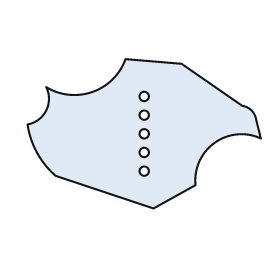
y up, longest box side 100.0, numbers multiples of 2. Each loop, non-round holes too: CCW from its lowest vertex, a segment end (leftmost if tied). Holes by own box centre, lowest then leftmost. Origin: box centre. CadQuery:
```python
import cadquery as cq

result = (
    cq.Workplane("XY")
    .moveTo(4.0, -32.0)
    .lineTo(22.0, -22.0)
    .threePointArc((30.0, -4.0), (50.0, -2.0))
    .lineTo(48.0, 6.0)
    .threePointArc((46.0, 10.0), (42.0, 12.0))
    .lineTo(16.0, 30.0)
    .lineTo(-8.0, 32.0)
    .threePointArc((-22.0, 18.0), (-42.0, 20.0))
    .threePointArc((-42.0, 10.0), (-50.0, 4.0))
    .threePointArc((-46.0, -8.0), (-38.0, -18.0))
    .close()
    .moveTo(0.0, -16.0)
    .circle(2.0)
    .moveTo(0.0, -8.0)
    .circle(2.0)
    .moveTo(0.0, 0.0)
    .circle(2.0)
    .moveTo(0.0, 8.0)
    .circle(2.0)
    .moveTo(0.0, 16.0)
    .circle(2.0)
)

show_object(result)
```